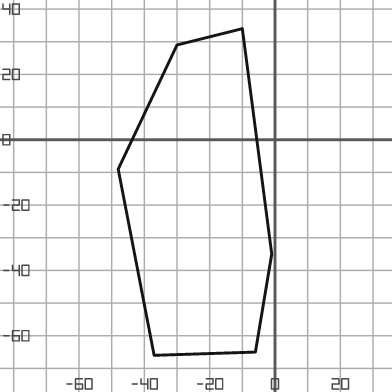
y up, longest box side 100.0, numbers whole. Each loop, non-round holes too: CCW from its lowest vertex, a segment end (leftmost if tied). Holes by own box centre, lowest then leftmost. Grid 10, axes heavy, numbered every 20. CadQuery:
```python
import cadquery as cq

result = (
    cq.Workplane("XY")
    .moveTo(-37.0, -66.0)
    .lineTo(-6.0, -65.0)
    .lineTo(-1.0, -35.0)
    .lineTo(-10.0, 34.0)
    .lineTo(-30.0, 29.0)
    .lineTo(-48.0, -9.0)
    .close()
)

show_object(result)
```